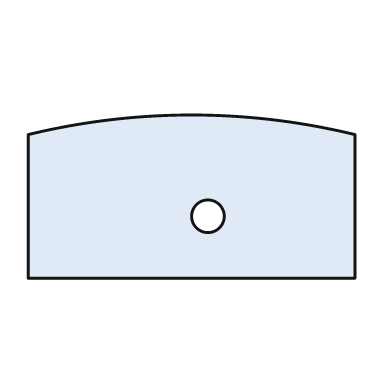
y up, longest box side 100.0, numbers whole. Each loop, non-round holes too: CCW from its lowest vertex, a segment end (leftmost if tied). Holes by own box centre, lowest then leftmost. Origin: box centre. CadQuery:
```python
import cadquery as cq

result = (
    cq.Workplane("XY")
    .moveTo(-50.0, -25.0)
    .lineTo(50.0, -25.0)
    .lineTo(50.0, 19.0)
    .threePointArc((0.0, 25.0), (-50.0, 19.0))
    .close()
    .moveTo(5.0, -6.0)
    .circle(5.0)
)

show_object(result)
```